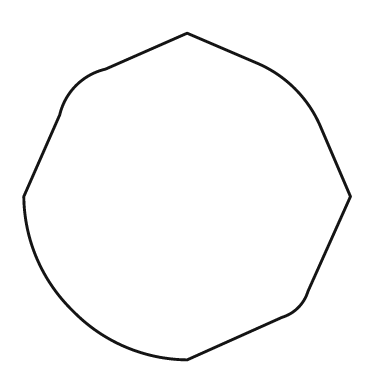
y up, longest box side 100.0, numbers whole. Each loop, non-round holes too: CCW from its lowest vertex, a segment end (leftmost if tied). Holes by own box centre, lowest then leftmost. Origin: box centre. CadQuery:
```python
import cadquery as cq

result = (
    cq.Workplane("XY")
    .moveTo(0.0, -50.0)
    .lineTo(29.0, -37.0)
    .threePointArc((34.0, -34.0), (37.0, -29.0))
    .lineTo(50.0, 0.0)
    .lineTo(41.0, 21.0)
    .threePointArc((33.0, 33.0), (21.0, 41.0))
    .lineTo(0.0, 50.0)
    .lineTo(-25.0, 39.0)
    .threePointArc((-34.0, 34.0), (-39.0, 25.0))
    .lineTo(-50.0, 0.0)
    .threePointArc((-46.0, -19.0), (-35.0, -35.0))
    .threePointArc((-19.0, -46.0), (0.0, -50.0))
    .close()
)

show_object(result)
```